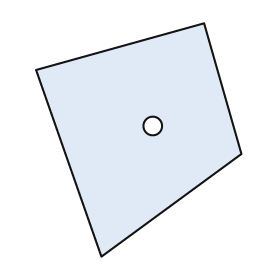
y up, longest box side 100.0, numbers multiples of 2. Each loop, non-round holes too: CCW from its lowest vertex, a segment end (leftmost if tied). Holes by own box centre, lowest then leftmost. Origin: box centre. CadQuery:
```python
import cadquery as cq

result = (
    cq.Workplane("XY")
    .moveTo(-16.0, -50.0)
    .lineTo(44.0, -6.0)
    .lineTo(28.0, 50.0)
    .lineTo(-44.0, 30.0)
    .close()
    .moveTo(6.0, 6.0)
    .circle(4.0)
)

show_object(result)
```